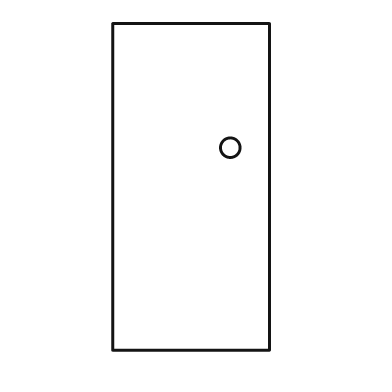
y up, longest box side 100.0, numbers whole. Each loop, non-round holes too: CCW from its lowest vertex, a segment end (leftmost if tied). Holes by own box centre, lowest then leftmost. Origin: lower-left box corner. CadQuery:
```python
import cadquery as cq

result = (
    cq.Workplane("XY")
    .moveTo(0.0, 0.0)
    .lineTo(48.0, 0.0)
    .lineTo(48.0, 100.0)
    .lineTo(0.0, 100.0)
    .close()
    .moveTo(36.0, 62.0)
    .circle(3.0)
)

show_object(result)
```